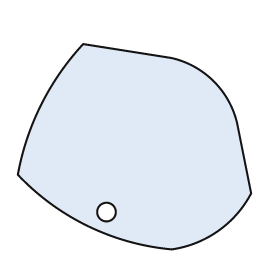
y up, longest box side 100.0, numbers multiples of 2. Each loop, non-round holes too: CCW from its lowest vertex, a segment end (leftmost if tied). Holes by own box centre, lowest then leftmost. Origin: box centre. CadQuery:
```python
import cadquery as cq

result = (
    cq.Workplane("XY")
    .moveTo(16.0, -44.0)
    .threePointArc((36.0, -36.0), (50.0, -20.0))
    .lineTo(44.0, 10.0)
    .threePointArc((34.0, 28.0), (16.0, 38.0))
    .lineTo(-22.0, 44.0)
    .threePointArc((-40.0, 18.0), (-50.0, -12.0))
    .threePointArc((-20.0, -34.0), (16.0, -44.0))
    .close()
    .moveTo(-12.0, -28.0)
    .circle(4.0)
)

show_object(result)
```